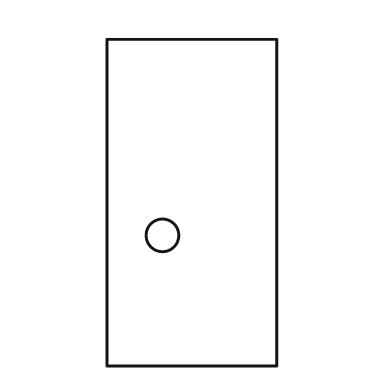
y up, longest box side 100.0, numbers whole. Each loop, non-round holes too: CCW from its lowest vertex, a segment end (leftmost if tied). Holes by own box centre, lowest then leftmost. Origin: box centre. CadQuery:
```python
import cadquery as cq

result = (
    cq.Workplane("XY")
    .moveTo(-26.0, -50.0)
    .lineTo(26.0, -50.0)
    .lineTo(26.0, 50.0)
    .lineTo(-26.0, 50.0)
    .close()
    .moveTo(-9.0, -10.0)
    .circle(5.0)
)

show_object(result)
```